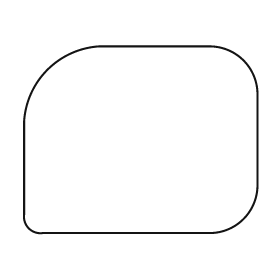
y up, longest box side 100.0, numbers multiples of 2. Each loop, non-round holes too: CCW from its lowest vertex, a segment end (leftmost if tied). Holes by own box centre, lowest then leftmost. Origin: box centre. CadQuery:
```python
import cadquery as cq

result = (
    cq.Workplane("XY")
    .moveTo(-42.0, -40.0)
    .lineTo(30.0, -40.0)
    .threePointArc((44.0, -34.0), (50.0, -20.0))
    .lineTo(50.0, 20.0)
    .threePointArc((44.0, 34.0), (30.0, 40.0))
    .lineTo(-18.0, 40.0)
    .threePointArc((-40.0, 30.0), (-50.0, 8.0))
    .lineTo(-50.0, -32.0)
    .threePointArc((-48.0, -38.0), (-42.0, -40.0))
    .close()
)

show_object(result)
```